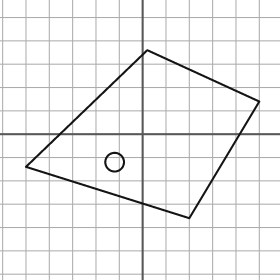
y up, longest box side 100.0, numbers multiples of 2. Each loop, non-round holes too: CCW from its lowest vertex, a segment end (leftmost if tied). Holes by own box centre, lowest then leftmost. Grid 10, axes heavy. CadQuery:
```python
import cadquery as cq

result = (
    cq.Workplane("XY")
    .moveTo(20.0, -36.0)
    .lineTo(50.0, 14.0)
    .lineTo(2.0, 36.0)
    .lineTo(-50.0, -14.0)
    .close()
    .moveTo(-12.0, -12.0)
    .circle(4.0)
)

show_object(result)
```